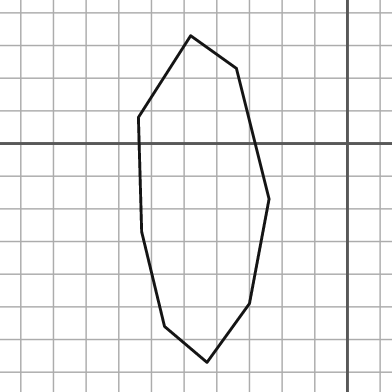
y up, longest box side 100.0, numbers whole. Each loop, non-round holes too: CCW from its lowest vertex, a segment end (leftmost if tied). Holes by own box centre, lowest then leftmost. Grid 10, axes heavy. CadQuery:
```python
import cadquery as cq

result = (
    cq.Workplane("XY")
    .moveTo(-43.0, -67.0)
    .lineTo(-30.0, -49.0)
    .lineTo(-24.0, -17.0)
    .lineTo(-34.0, 23.0)
    .lineTo(-48.0, 33.0)
    .lineTo(-64.0, 8.0)
    .lineTo(-63.0, -27.0)
    .lineTo(-56.0, -56.0)
    .close()
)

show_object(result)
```